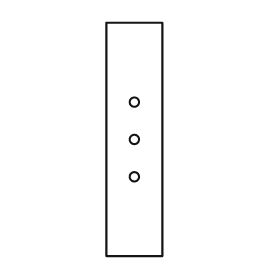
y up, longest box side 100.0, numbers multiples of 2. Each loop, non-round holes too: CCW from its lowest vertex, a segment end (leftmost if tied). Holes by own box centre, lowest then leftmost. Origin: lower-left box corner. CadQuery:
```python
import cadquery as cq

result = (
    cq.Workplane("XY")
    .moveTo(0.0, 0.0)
    .lineTo(24.0, 0.0)
    .lineTo(24.0, 100.0)
    .lineTo(0.0, 100.0)
    .close()
    .moveTo(12.0, 34.0)
    .circle(2.0)
    .moveTo(12.0, 50.0)
    .circle(2.0)
    .moveTo(12.0, 66.0)
    .circle(2.0)
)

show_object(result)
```